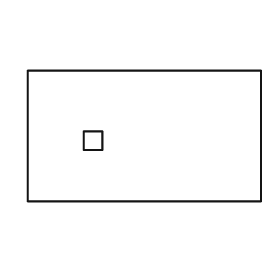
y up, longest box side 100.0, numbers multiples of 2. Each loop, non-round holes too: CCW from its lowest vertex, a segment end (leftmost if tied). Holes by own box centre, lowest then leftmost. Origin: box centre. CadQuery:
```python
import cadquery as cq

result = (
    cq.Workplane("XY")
    .moveTo(-50.0, -28.0)
    .lineTo(50.0, -28.0)
    .lineTo(50.0, 28.0)
    .lineTo(-50.0, 28.0)
    .close()
    .moveTo(-26.0, -6.0)
    .lineTo(-18.0, -6.0)
    .lineTo(-18.0, 2.0)
    .lineTo(-26.0, 2.0)
    .close()
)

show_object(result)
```